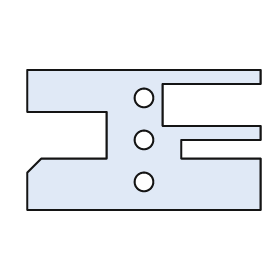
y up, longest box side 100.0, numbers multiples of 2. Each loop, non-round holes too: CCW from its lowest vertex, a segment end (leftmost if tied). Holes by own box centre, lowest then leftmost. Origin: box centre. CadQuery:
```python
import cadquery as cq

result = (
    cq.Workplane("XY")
    .moveTo(-50.0, -30.0)
    .lineTo(50.0, -30.0)
    .lineTo(50.0, -8.0)
    .lineTo(16.0, -8.0)
    .lineTo(16.0, 0.0)
    .lineTo(50.0, 0.0)
    .lineTo(50.0, 6.0)
    .lineTo(8.0, 6.0)
    .lineTo(8.0, 24.0)
    .lineTo(50.0, 24.0)
    .lineTo(50.0, 30.0)
    .lineTo(-50.0, 30.0)
    .lineTo(-50.0, 12.0)
    .lineTo(-16.0, 12.0)
    .lineTo(-16.0, -8.0)
    .lineTo(-44.0, -8.0)
    .lineTo(-50.0, -14.0)
    .close()
    .moveTo(0.0, -18.0)
    .circle(4.0)
    .moveTo(0.0, 0.0)
    .circle(4.0)
    .moveTo(0.0, 18.0)
    .circle(4.0)
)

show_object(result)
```